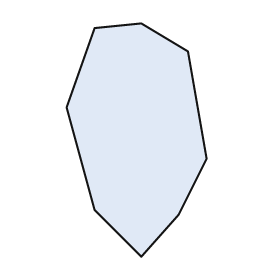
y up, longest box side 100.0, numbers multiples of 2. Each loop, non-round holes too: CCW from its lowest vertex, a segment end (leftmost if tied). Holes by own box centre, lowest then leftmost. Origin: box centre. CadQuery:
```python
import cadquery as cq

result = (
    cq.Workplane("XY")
    .moveTo(2.0, -50.0)
    .lineTo(18.0, -32.0)
    .lineTo(30.0, -8.0)
    .lineTo(22.0, 38.0)
    .lineTo(2.0, 50.0)
    .lineTo(-18.0, 48.0)
    .lineTo(-30.0, 14.0)
    .lineTo(-18.0, -30.0)
    .close()
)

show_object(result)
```